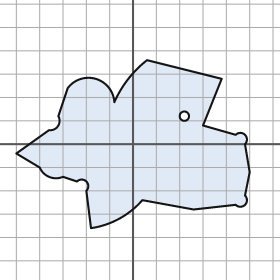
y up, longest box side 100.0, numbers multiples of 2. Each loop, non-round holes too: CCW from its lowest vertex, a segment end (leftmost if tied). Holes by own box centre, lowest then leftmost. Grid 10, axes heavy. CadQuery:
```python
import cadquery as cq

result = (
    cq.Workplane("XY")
    .moveTo(-18.0, -36.0)
    .threePointArc((-6.0, -32.0), (4.0, -24.0))
    .lineTo(26.0, -28.0)
    .lineTo(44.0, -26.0)
    .threePointArc((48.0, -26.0), (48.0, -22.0))
    .lineTo(50.0, -12.0)
    .lineTo(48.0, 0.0)
    .threePointArc((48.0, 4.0), (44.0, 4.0))
    .lineTo(30.0, 8.0)
    .lineTo(38.0, 28.0)
    .lineTo(6.0, 36.0)
    .threePointArc((-2.0, 28.0), (-8.0, 18.0))
    .threePointArc((-16.0, 28.0), (-28.0, 24.0))
    .lineTo(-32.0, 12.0)
    .threePointArc((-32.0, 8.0), (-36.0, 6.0))
    .lineTo(-50.0, -4.0)
    .lineTo(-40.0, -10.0)
    .threePointArc((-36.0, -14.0), (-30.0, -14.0))
    .lineTo(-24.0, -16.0)
    .threePointArc((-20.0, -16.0), (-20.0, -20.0))
    .close()
    .moveTo(22.0, 12.0)
    .circle(2.0)
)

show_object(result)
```